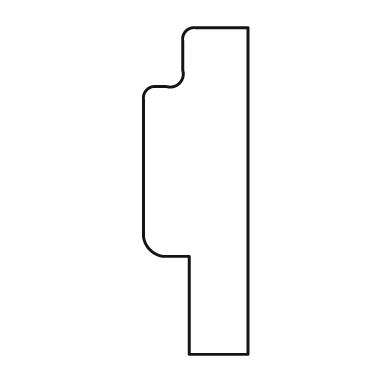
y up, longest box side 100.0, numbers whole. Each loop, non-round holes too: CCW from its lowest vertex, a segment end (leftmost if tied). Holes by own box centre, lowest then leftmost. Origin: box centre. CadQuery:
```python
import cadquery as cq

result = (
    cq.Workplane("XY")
    .moveTo(-2.0, -50.0)
    .lineTo(16.0, -50.0)
    .lineTo(16.0, 50.0)
    .lineTo(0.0, 50.0)
    .threePointArc((-3.0, 49.0), (-4.0, 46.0))
    .lineTo(-4.0, 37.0)
    .threePointArc((-5.0, 33.0), (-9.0, 32.0))
    .lineTo(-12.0, 32.0)
    .threePointArc((-15.0, 31.0), (-16.0, 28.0))
    .lineTo(-16.0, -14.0)
    .threePointArc((-14.0, -18.0), (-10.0, -20.0))
    .lineTo(-2.0, -20.0)
    .close()
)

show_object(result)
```